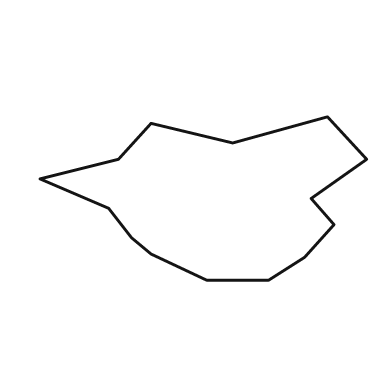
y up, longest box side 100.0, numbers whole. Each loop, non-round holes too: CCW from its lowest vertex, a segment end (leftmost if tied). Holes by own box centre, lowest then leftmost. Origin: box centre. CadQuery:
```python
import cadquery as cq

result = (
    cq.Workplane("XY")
    .moveTo(1.0, -25.0)
    .lineTo(20.0, -25.0)
    .lineTo(31.0, -18.0)
    .lineTo(40.0, -8.0)
    .lineTo(33.0, 0.0)
    .lineTo(50.0, 12.0)
    .lineTo(38.0, 25.0)
    .lineTo(9.0, 17.0)
    .lineTo(-16.0, 23.0)
    .lineTo(-26.0, 12.0)
    .lineTo(-50.0, 6.0)
    .lineTo(-29.0, -3.0)
    .lineTo(-22.0, -12.0)
    .lineTo(-16.0, -17.0)
    .close()
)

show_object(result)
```